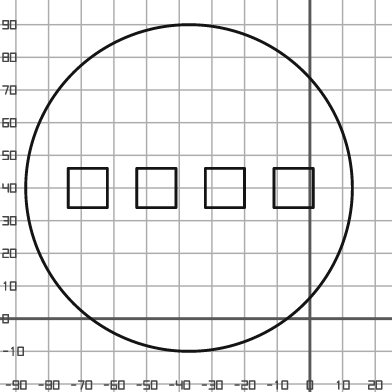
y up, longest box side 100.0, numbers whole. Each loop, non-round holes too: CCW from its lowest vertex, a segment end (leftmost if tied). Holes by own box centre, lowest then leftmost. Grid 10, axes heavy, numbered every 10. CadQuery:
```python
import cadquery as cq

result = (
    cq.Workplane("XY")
    .moveTo(-37.0, 40.0)
    .circle(50.0)
    .moveTo(-74.0, 34.0)
    .lineTo(-62.0, 34.0)
    .lineTo(-62.0, 46.0)
    .lineTo(-74.0, 46.0)
    .close()
    .moveTo(-53.0, 34.0)
    .lineTo(-41.0, 34.0)
    .lineTo(-41.0, 46.0)
    .lineTo(-53.0, 46.0)
    .close()
    .moveTo(-32.0, 34.0)
    .lineTo(-20.0, 34.0)
    .lineTo(-20.0, 46.0)
    .lineTo(-32.0, 46.0)
    .close()
    .moveTo(-11.0, 34.0)
    .lineTo(1.0, 34.0)
    .lineTo(1.0, 46.0)
    .lineTo(-11.0, 46.0)
    .close()
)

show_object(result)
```